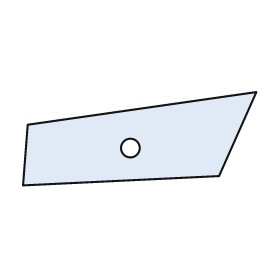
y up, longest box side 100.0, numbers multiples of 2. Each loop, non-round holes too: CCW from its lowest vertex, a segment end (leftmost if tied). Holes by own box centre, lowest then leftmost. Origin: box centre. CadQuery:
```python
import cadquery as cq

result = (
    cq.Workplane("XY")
    .moveTo(-50.0, -20.0)
    .lineTo(34.0, -16.0)
    .lineTo(50.0, 20.0)
    .lineTo(-48.0, 6.0)
    .close()
    .moveTo(-4.0, -4.0)
    .circle(4.0)
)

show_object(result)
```